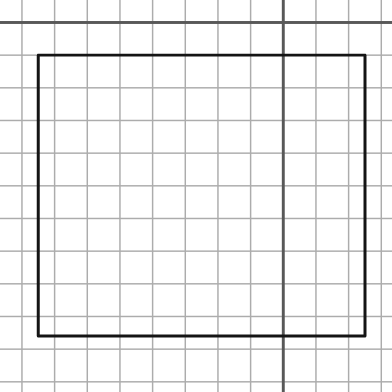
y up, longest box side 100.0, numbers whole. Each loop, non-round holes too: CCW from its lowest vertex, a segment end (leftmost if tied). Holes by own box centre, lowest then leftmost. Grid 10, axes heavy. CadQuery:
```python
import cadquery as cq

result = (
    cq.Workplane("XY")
    .moveTo(-75.0, -96.0)
    .lineTo(25.0, -96.0)
    .lineTo(25.0, -10.0)
    .lineTo(-75.0, -10.0)
    .close()
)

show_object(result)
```